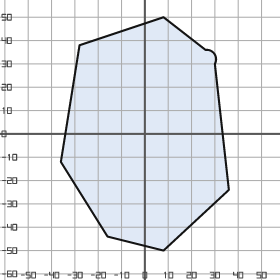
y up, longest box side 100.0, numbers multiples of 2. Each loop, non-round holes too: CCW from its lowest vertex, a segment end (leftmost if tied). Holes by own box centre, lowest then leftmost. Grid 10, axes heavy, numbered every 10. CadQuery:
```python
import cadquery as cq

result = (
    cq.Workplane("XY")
    .moveTo(8.0, -50.0)
    .lineTo(36.0, -24.0)
    .lineTo(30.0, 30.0)
    .threePointArc((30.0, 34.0), (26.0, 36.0))
    .lineTo(8.0, 50.0)
    .lineTo(-28.0, 38.0)
    .lineTo(-36.0, -12.0)
    .lineTo(-16.0, -44.0)
    .close()
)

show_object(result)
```